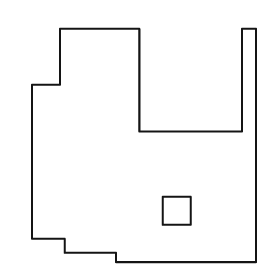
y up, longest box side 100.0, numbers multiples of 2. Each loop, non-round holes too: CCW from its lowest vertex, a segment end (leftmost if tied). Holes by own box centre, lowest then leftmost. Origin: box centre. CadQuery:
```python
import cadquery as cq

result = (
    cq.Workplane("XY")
    .moveTo(-12.0, -50.0)
    .lineTo(48.0, -50.0)
    .lineTo(48.0, 50.0)
    .lineTo(42.0, 50.0)
    .lineTo(42.0, 6.0)
    .lineTo(-2.0, 6.0)
    .lineTo(-2.0, 50.0)
    .lineTo(-36.0, 50.0)
    .lineTo(-36.0, 26.0)
    .lineTo(-48.0, 26.0)
    .lineTo(-48.0, -40.0)
    .lineTo(-34.0, -40.0)
    .lineTo(-34.0, -46.0)
    .lineTo(-12.0, -46.0)
    .close()
    .moveTo(8.0, -34.0)
    .lineTo(20.0, -34.0)
    .lineTo(20.0, -22.0)
    .lineTo(8.0, -22.0)
    .close()
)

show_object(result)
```